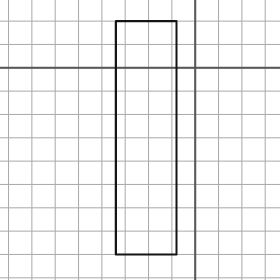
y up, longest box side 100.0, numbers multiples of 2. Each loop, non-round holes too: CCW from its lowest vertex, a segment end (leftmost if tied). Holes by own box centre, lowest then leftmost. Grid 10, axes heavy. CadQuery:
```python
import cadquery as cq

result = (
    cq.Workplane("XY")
    .moveTo(-34.0, -80.0)
    .lineTo(-8.0, -80.0)
    .lineTo(-8.0, 20.0)
    .lineTo(-34.0, 20.0)
    .close()
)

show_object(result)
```